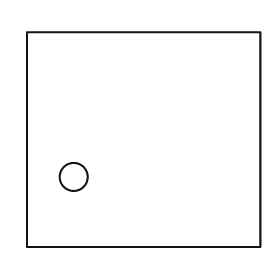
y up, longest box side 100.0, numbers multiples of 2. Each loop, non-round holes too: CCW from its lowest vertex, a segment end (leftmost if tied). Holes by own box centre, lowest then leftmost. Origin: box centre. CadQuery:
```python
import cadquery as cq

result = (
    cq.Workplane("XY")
    .moveTo(-50.0, -46.0)
    .lineTo(50.0, -46.0)
    .lineTo(50.0, 46.0)
    .lineTo(-50.0, 46.0)
    .close()
    .moveTo(-30.0, -16.0)
    .circle(6.0)
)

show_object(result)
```